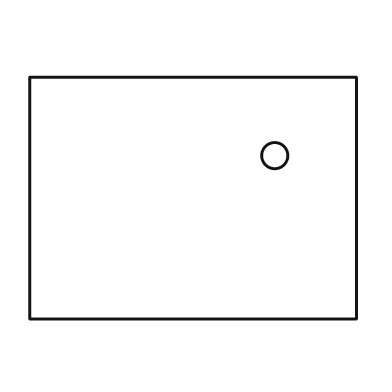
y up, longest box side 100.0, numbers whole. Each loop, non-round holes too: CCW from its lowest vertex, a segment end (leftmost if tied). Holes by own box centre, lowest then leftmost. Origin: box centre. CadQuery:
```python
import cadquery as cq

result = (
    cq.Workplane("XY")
    .moveTo(-50.0, -37.0)
    .lineTo(50.0, -37.0)
    .lineTo(50.0, 37.0)
    .lineTo(-50.0, 37.0)
    .close()
    .moveTo(25.0, 13.0)
    .circle(4.0)
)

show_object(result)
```